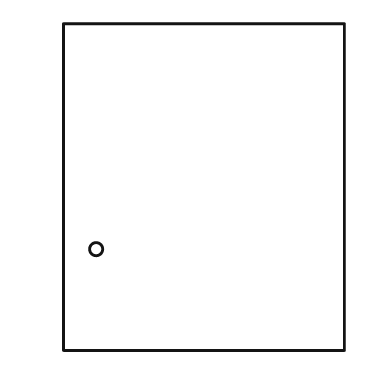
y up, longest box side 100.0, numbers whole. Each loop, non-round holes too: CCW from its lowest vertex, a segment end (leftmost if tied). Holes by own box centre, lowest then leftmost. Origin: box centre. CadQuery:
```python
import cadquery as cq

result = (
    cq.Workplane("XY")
    .moveTo(-43.0, -50.0)
    .lineTo(43.0, -50.0)
    .lineTo(43.0, 50.0)
    .lineTo(-43.0, 50.0)
    .close()
    .moveTo(-33.0, -19.0)
    .circle(2.0)
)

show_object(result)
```